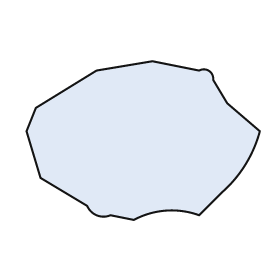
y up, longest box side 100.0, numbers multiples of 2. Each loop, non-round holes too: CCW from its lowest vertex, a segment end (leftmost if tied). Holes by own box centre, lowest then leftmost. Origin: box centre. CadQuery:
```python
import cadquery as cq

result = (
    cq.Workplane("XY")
    .moveTo(-4.0, -34.0)
    .threePointArc((10.0, -30.0), (24.0, -32.0))
    .lineTo(34.0, -22.0)
    .threePointArc((44.0, -10.0), (50.0, 4.0))
    .lineTo(36.0, 16.0)
    .lineTo(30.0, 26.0)
    .threePointArc((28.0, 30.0), (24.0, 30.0))
    .lineTo(4.0, 34.0)
    .lineTo(-20.0, 30.0)
    .lineTo(-46.0, 14.0)
    .lineTo(-50.0, 4.0)
    .lineTo(-44.0, -16.0)
    .lineTo(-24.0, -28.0)
    .threePointArc((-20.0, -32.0), (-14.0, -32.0))
    .close()
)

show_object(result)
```